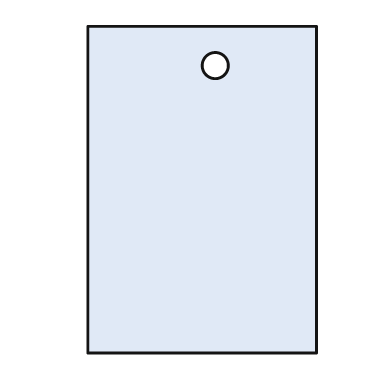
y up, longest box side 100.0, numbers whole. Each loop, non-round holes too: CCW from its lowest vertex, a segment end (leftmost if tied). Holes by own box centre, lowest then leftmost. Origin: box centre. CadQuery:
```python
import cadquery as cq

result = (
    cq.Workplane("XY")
    .moveTo(-35.0, -50.0)
    .lineTo(35.0, -50.0)
    .lineTo(35.0, 50.0)
    .lineTo(-35.0, 50.0)
    .close()
    .moveTo(4.0, 38.0)
    .circle(4.0)
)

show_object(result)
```